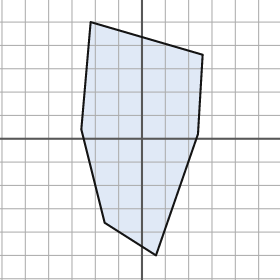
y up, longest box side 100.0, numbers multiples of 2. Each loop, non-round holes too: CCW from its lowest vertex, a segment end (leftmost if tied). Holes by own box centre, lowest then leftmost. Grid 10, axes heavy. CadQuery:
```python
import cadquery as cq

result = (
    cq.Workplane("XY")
    .moveTo(6.0, -50.0)
    .lineTo(24.0, 2.0)
    .lineTo(26.0, 36.0)
    .lineTo(-22.0, 50.0)
    .lineTo(-26.0, 4.0)
    .lineTo(-16.0, -36.0)
    .close()
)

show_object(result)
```